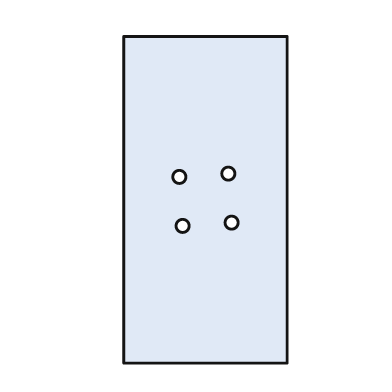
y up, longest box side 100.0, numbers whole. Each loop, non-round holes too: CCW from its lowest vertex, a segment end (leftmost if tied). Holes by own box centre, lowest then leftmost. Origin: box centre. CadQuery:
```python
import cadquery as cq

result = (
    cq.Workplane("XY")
    .moveTo(-25.0, -50.0)
    .lineTo(25.0, -50.0)
    .lineTo(25.0, 50.0)
    .lineTo(-25.0, 50.0)
    .close()
    .moveTo(-7.0, -8.0)
    .circle(2.0)
    .moveTo(8.0, -7.0)
    .circle(2.0)
    .moveTo(-8.0, 7.0)
    .circle(2.0)
    .moveTo(7.0, 8.0)
    .circle(2.0)
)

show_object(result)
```